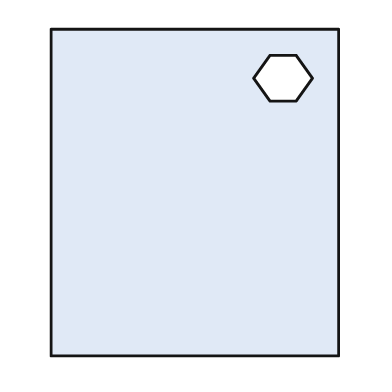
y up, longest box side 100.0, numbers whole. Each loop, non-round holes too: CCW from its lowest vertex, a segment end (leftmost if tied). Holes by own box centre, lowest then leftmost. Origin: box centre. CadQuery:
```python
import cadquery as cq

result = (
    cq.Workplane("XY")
    .moveTo(-44.0, -50.0)
    .lineTo(44.0, -50.0)
    .lineTo(44.0, 50.0)
    .lineTo(-44.0, 50.0)
    .close()
    .moveTo(23.0, 28.0)
    .lineTo(31.0, 28.0)
    .lineTo(36.0, 35.0)
    .lineTo(31.0, 42.0)
    .lineTo(23.0, 42.0)
    .lineTo(18.0, 35.0)
    .close()
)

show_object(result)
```